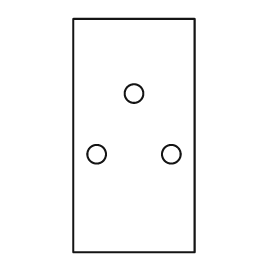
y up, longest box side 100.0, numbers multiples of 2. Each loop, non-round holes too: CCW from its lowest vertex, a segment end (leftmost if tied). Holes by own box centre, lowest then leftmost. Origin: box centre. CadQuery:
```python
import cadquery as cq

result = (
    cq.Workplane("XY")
    .moveTo(-26.0, -50.0)
    .lineTo(26.0, -50.0)
    .lineTo(26.0, 50.0)
    .lineTo(-26.0, 50.0)
    .close()
    .moveTo(-16.0, -8.0)
    .circle(4.0)
    .moveTo(16.0, -8.0)
    .circle(4.0)
    .moveTo(0.0, 18.0)
    .circle(4.0)
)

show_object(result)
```